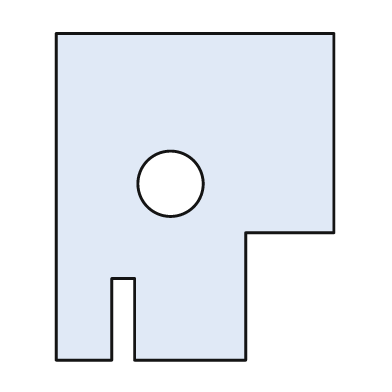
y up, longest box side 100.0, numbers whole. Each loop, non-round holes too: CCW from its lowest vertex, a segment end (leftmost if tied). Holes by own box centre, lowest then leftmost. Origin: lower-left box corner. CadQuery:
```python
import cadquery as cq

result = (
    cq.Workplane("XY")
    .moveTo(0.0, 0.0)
    .lineTo(17.0, 0.0)
    .lineTo(17.0, 25.0)
    .lineTo(24.0, 25.0)
    .lineTo(24.0, 0.0)
    .lineTo(58.0, 0.0)
    .lineTo(58.0, 39.0)
    .lineTo(85.0, 39.0)
    .lineTo(85.0, 100.0)
    .lineTo(0.0, 100.0)
    .close()
    .moveTo(35.0, 54.0)
    .circle(10.0)
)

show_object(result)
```